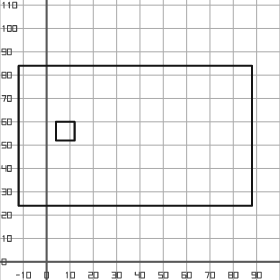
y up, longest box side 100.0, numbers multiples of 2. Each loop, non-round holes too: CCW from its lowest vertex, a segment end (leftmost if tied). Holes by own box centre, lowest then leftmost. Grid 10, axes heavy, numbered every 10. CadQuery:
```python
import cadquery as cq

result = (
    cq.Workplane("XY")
    .moveTo(-12.0, 24.0)
    .lineTo(88.0, 24.0)
    .lineTo(88.0, 84.0)
    .lineTo(-12.0, 84.0)
    .close()
    .moveTo(4.0, 52.0)
    .lineTo(12.0, 52.0)
    .lineTo(12.0, 60.0)
    .lineTo(4.0, 60.0)
    .close()
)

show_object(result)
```